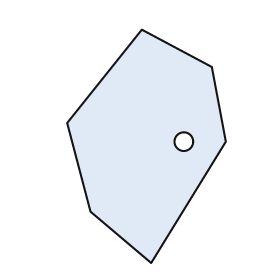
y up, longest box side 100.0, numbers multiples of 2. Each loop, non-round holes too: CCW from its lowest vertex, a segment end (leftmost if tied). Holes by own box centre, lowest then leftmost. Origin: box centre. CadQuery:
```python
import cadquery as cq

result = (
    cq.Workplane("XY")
    .moveTo(2.0, -50.0)
    .lineTo(34.0, 2.0)
    .lineTo(28.0, 34.0)
    .lineTo(-2.0, 50.0)
    .lineTo(-34.0, 10.0)
    .lineTo(-24.0, -28.0)
    .close()
    .moveTo(16.0, 2.0)
    .circle(4.0)
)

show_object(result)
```